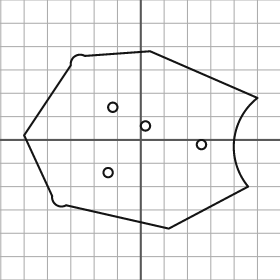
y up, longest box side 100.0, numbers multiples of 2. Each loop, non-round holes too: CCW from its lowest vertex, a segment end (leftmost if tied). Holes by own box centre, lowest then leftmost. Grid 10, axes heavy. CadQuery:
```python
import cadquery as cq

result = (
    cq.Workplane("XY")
    .moveTo(12.0, -38.0)
    .lineTo(46.0, -20.0)
    .threePointArc((40.0, 0.0), (50.0, 18.0))
    .lineTo(4.0, 38.0)
    .lineTo(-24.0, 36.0)
    .threePointArc((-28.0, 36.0), (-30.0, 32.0))
    .lineTo(-50.0, 2.0)
    .lineTo(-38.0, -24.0)
    .threePointArc((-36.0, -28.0), (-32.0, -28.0))
    .close()
    .moveTo(-14.0, -14.0)
    .circle(2.0)
    .moveTo(26.0, -2.0)
    .circle(2.0)
    .moveTo(2.0, 6.0)
    .circle(2.0)
    .moveTo(-12.0, 14.0)
    .circle(2.0)
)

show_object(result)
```